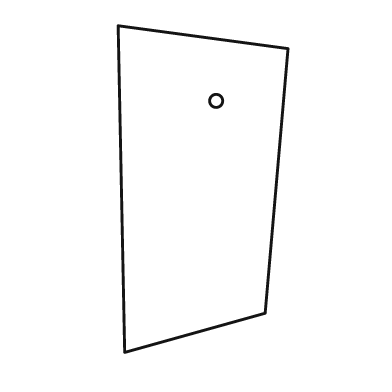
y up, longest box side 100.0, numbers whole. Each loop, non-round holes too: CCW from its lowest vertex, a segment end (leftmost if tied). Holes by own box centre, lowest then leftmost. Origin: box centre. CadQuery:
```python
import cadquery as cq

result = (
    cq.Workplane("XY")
    .moveTo(-24.0, -50.0)
    .lineTo(19.0, -38.0)
    .lineTo(26.0, 43.0)
    .lineTo(-26.0, 50.0)
    .close()
    .moveTo(4.0, 27.0)
    .circle(2.0)
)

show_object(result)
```